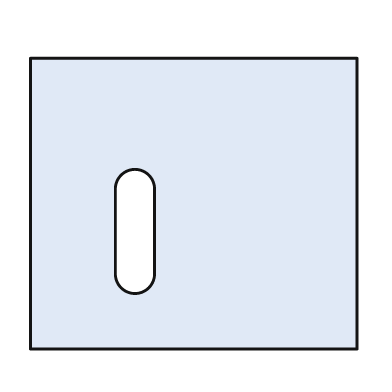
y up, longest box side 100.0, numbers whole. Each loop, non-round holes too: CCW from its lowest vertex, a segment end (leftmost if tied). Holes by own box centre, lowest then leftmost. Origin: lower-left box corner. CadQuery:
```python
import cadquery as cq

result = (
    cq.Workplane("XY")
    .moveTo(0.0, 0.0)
    .lineTo(100.0, 0.0)
    .lineTo(100.0, 89.0)
    .lineTo(0.0, 89.0)
    .close()
    .moveTo(26.0, 23.0)
    .threePointArc((32.0, 17.0), (38.0, 23.0))
    .lineTo(38.0, 49.0)
    .threePointArc((32.0, 55.0), (26.0, 49.0))
    .close()
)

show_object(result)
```